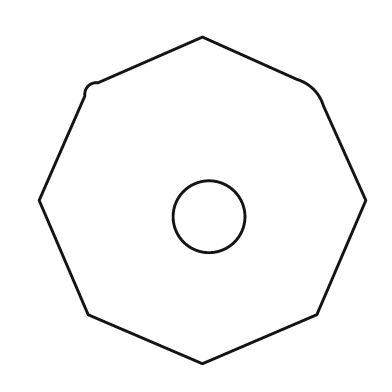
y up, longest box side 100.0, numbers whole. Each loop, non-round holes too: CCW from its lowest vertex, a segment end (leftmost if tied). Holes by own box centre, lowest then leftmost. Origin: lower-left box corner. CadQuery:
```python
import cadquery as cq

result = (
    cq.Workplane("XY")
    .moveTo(50.0, 0.0)
    .lineTo(85.0, 15.0)
    .lineTo(100.0, 50.0)
    .lineTo(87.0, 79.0)
    .threePointArc((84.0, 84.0), (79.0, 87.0))
    .lineTo(50.0, 100.0)
    .lineTo(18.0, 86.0)
    .threePointArc((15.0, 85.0), (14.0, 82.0))
    .lineTo(0.0, 50.0)
    .lineTo(15.0, 15.0)
    .close()
    .moveTo(52.0, 45.0)
    .circle(11.0)
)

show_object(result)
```